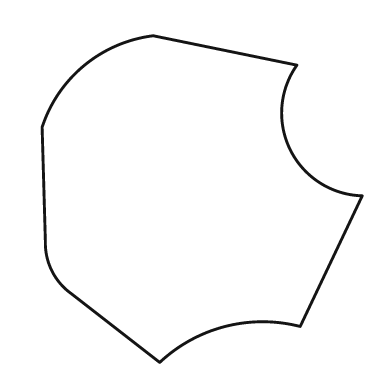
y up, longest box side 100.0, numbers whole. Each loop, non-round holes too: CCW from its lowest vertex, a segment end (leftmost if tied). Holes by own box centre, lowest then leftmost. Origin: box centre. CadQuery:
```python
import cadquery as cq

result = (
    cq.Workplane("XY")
    .moveTo(-13.0, -50.0)
    .threePointArc((7.0, -39.0), (30.0, -39.0))
    .lineTo(49.0, 1.0)
    .threePointArc((27.0, 15.0), (29.0, 41.0))
    .lineTo(-15.0, 50.0)
    .threePointArc((-36.0, 41.0), (-49.0, 22.0))
    .lineTo(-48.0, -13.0)
    .threePointArc((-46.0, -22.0), (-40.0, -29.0))
    .close()
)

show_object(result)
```